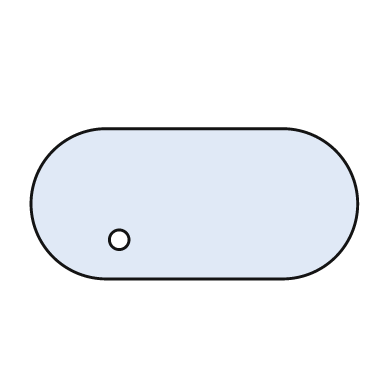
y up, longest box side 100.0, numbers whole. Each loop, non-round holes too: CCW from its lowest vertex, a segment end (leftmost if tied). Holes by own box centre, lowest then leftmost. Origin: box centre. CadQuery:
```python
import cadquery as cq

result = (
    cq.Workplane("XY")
    .moveTo(-27.0, -23.0)
    .lineTo(27.0, -23.0)
    .threePointArc((50.0, 0.0), (27.0, 23.0))
    .lineTo(-27.0, 23.0)
    .threePointArc((-50.0, 0.0), (-27.0, -23.0))
    .close()
    .moveTo(-23.0, -11.0)
    .circle(3.0)
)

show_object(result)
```